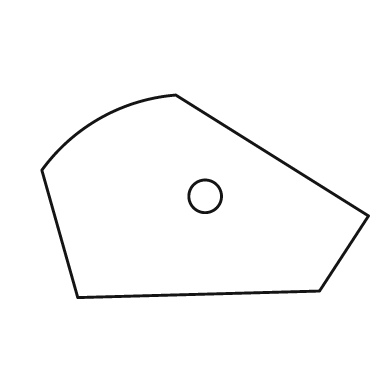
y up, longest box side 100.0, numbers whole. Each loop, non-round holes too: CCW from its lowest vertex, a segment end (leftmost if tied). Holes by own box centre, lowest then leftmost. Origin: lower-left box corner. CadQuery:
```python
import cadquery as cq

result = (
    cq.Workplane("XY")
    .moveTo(11.0, 0.0)
    .lineTo(85.0, 2.0)
    .lineTo(100.0, 25.0)
    .lineTo(41.0, 62.0)
    .threePointArc((18.0, 55.0), (0.0, 39.0))
    .close()
    .moveTo(50.0, 31.0)
    .circle(5.0)
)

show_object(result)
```